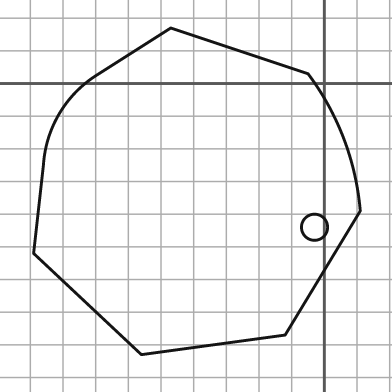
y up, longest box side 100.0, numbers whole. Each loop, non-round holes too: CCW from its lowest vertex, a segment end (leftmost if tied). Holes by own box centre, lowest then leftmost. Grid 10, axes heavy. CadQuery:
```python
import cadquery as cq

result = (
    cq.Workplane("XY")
    .moveTo(-56.0, -83.0)
    .lineTo(-12.0, -77.0)
    .lineTo(11.0, -39.0)
    .threePointArc((6.0, -17.0), (-5.0, 3.0))
    .lineTo(-47.0, 17.0)
    .lineTo(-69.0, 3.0)
    .threePointArc((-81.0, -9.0), (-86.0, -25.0))
    .lineTo(-89.0, -52.0)
    .close()
    .moveTo(-3.0, -44.0)
    .circle(4.0)
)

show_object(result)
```